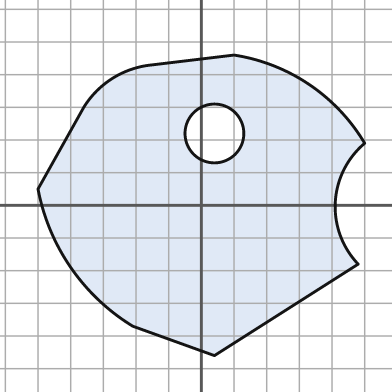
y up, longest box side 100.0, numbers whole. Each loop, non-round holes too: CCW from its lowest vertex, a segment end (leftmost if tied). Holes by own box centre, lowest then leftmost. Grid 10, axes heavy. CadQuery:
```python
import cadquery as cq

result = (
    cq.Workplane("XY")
    .moveTo(4.0, -46.0)
    .lineTo(48.0, -18.0)
    .threePointArc((41.0, 1.0), (50.0, 19.0))
    .threePointArc((33.0, 37.0), (10.0, 46.0))
    .lineTo(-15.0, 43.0)
    .threePointArc((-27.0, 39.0), (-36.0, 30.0))
    .lineTo(-50.0, 5.0)
    .threePointArc((-40.0, -19.0), (-21.0, -37.0))
    .close()
    .moveTo(4.0, 22.0)
    .circle(9.0)
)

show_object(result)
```